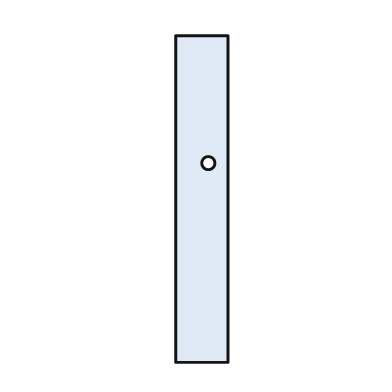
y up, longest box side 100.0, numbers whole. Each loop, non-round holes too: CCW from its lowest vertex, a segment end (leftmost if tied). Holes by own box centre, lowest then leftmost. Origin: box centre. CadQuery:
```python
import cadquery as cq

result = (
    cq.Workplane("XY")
    .moveTo(-8.0, -50.0)
    .lineTo(8.0, -50.0)
    .lineTo(8.0, 50.0)
    .lineTo(-8.0, 50.0)
    .close()
    .moveTo(2.0, 11.0)
    .circle(2.0)
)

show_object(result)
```